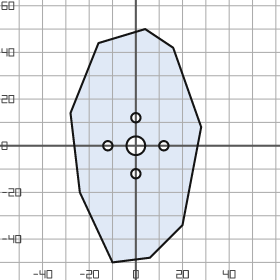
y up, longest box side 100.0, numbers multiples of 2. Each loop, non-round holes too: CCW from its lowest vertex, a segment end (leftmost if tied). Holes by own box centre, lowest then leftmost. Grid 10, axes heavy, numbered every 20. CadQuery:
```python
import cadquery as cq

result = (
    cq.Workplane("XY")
    .moveTo(-10.0, -50.0)
    .lineTo(6.0, -48.0)
    .lineTo(20.0, -34.0)
    .lineTo(28.0, 8.0)
    .lineTo(16.0, 42.0)
    .lineTo(4.0, 50.0)
    .lineTo(-16.0, 44.0)
    .lineTo(-28.0, 14.0)
    .lineTo(-24.0, -20.0)
    .close()
    .moveTo(0.0, -12.0)
    .circle(2.0)
    .moveTo(-12.0, 0.0)
    .circle(2.0)
    .moveTo(0.0, 0.0)
    .circle(4.0)
    .moveTo(12.0, 0.0)
    .circle(2.0)
    .moveTo(0.0, 12.0)
    .circle(2.0)
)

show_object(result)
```